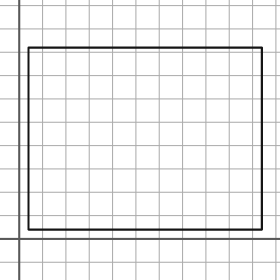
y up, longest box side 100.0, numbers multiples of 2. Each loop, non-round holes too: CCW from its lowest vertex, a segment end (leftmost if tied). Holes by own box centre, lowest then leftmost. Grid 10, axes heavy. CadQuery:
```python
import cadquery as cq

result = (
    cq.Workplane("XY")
    .moveTo(4.0, 4.0)
    .lineTo(104.0, 4.0)
    .lineTo(104.0, 82.0)
    .lineTo(4.0, 82.0)
    .close()
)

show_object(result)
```